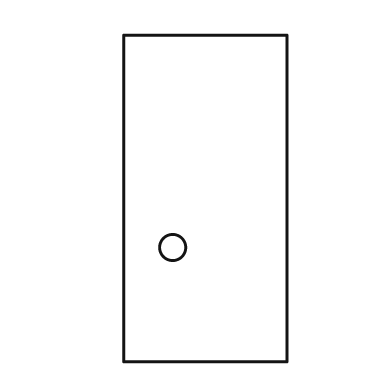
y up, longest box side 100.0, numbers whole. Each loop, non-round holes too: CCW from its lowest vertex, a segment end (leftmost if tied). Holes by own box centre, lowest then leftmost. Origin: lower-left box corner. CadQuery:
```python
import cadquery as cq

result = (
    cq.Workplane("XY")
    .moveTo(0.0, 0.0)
    .lineTo(50.0, 0.0)
    .lineTo(50.0, 100.0)
    .lineTo(0.0, 100.0)
    .close()
    .moveTo(15.0, 35.0)
    .circle(4.0)
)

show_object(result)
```